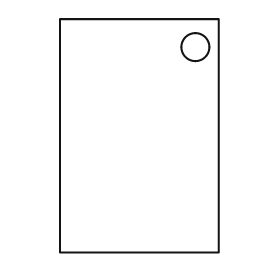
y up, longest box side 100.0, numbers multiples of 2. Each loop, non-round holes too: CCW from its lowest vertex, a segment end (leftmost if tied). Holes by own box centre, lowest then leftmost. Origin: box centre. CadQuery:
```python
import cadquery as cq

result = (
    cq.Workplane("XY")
    .moveTo(-34.0, -50.0)
    .lineTo(34.0, -50.0)
    .lineTo(34.0, 50.0)
    .lineTo(-34.0, 50.0)
    .close()
    .moveTo(24.0, 38.0)
    .circle(6.0)
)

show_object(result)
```